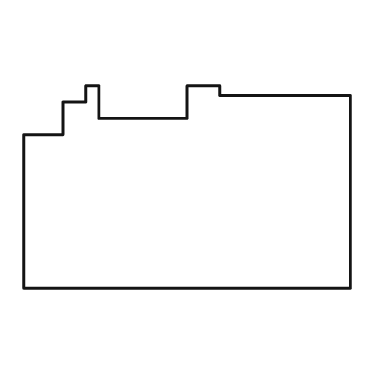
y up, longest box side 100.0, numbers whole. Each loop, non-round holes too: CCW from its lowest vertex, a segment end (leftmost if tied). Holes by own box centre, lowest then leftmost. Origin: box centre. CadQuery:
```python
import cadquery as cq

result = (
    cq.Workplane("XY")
    .moveTo(-50.0, -31.0)
    .lineTo(50.0, -31.0)
    .lineTo(50.0, 28.0)
    .lineTo(10.0, 28.0)
    .lineTo(10.0, 31.0)
    .lineTo(0.0, 31.0)
    .lineTo(0.0, 21.0)
    .lineTo(-27.0, 21.0)
    .lineTo(-27.0, 31.0)
    .lineTo(-31.0, 31.0)
    .lineTo(-31.0, 26.0)
    .lineTo(-38.0, 26.0)
    .lineTo(-38.0, 16.0)
    .lineTo(-50.0, 16.0)
    .close()
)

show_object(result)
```